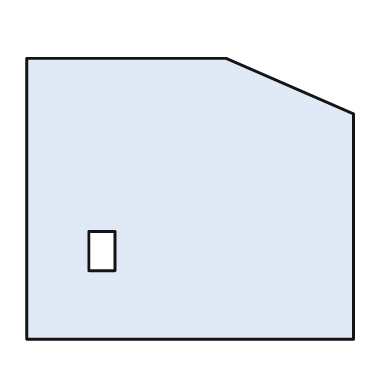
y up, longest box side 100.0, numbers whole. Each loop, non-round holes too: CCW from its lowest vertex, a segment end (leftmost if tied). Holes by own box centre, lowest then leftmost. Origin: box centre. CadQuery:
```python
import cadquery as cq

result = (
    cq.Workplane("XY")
    .moveTo(-50.0, -43.0)
    .lineTo(50.0, -43.0)
    .lineTo(50.0, 26.0)
    .lineTo(11.0, 43.0)
    .lineTo(-50.0, 43.0)
    .close()
    .moveTo(-31.0, -22.0)
    .lineTo(-23.0, -22.0)
    .lineTo(-23.0, -10.0)
    .lineTo(-31.0, -10.0)
    .close()
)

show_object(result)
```